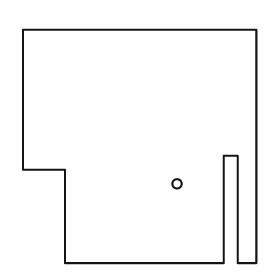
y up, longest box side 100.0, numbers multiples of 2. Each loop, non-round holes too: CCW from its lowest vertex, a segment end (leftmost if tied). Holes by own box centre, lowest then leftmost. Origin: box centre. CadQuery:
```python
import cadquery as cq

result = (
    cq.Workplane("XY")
    .moveTo(-32.0, -50.0)
    .lineTo(36.0, -50.0)
    .lineTo(36.0, -4.0)
    .lineTo(42.0, -4.0)
    .lineTo(42.0, -50.0)
    .lineTo(50.0, -50.0)
    .lineTo(50.0, 50.0)
    .lineTo(-50.0, 50.0)
    .lineTo(-50.0, -10.0)
    .lineTo(-32.0, -10.0)
    .close()
    .moveTo(16.0, -16.0)
    .circle(2.0)
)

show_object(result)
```